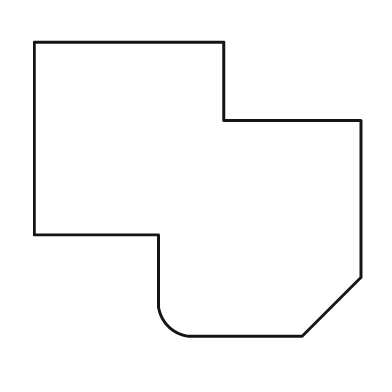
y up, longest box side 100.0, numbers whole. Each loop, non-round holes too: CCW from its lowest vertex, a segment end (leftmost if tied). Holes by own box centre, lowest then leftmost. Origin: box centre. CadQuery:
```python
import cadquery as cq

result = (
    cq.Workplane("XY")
    .moveTo(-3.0, -45.0)
    .lineTo(32.0, -45.0)
    .lineTo(50.0, -27.0)
    .lineTo(50.0, 21.0)
    .lineTo(8.0, 21.0)
    .lineTo(8.0, 45.0)
    .lineTo(-50.0, 45.0)
    .lineTo(-50.0, -14.0)
    .lineTo(-12.0, -14.0)
    .lineTo(-12.0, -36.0)
    .threePointArc((-9.0, -42.0), (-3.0, -45.0))
    .close()
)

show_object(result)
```